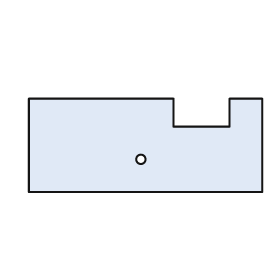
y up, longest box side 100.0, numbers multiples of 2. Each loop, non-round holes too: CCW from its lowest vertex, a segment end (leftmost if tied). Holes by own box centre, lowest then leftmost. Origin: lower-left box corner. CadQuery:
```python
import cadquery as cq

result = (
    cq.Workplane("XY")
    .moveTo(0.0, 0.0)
    .lineTo(100.0, 0.0)
    .lineTo(100.0, 40.0)
    .lineTo(86.0, 40.0)
    .lineTo(86.0, 28.0)
    .lineTo(62.0, 28.0)
    .lineTo(62.0, 40.0)
    .lineTo(0.0, 40.0)
    .close()
    .moveTo(48.0, 14.0)
    .circle(2.0)
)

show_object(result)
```